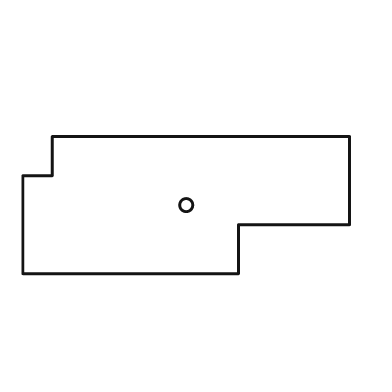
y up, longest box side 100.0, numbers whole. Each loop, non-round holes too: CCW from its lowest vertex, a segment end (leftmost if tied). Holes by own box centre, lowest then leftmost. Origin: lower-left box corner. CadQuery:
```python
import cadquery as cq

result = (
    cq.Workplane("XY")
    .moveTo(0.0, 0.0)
    .lineTo(66.0, 0.0)
    .lineTo(66.0, 15.0)
    .lineTo(100.0, 15.0)
    .lineTo(100.0, 42.0)
    .lineTo(9.0, 42.0)
    .lineTo(9.0, 30.0)
    .lineTo(0.0, 30.0)
    .close()
    .moveTo(50.0, 21.0)
    .circle(2.0)
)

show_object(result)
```